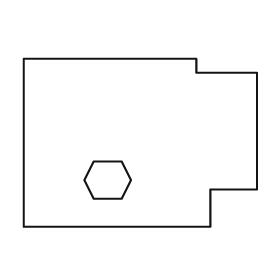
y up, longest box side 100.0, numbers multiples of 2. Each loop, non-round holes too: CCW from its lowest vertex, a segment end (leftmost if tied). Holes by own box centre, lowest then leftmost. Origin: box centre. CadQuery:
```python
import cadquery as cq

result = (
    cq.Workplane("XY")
    .moveTo(-50.0, -36.0)
    .lineTo(30.0, -36.0)
    .lineTo(30.0, -20.0)
    .lineTo(50.0, -20.0)
    .lineTo(50.0, 30.0)
    .lineTo(24.0, 30.0)
    .lineTo(24.0, 36.0)
    .lineTo(-50.0, 36.0)
    .close()
    .moveTo(-20.0, -24.0)
    .lineTo(-8.0, -24.0)
    .lineTo(-4.0, -16.0)
    .lineTo(-8.0, -8.0)
    .lineTo(-20.0, -8.0)
    .lineTo(-24.0, -16.0)
    .close()
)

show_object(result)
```